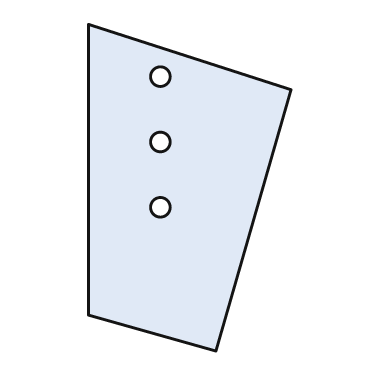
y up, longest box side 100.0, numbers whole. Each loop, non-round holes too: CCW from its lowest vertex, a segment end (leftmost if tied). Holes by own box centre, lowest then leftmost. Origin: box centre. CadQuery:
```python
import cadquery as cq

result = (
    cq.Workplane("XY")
    .moveTo(8.0, -50.0)
    .lineTo(31.0, 30.0)
    .lineTo(-31.0, 50.0)
    .lineTo(-31.0, -39.0)
    .close()
    .moveTo(-9.0, -6.0)
    .circle(3.0)
    .moveTo(-9.0, 14.0)
    .circle(3.0)
    .moveTo(-9.0, 34.0)
    .circle(3.0)
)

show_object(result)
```